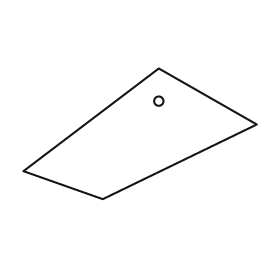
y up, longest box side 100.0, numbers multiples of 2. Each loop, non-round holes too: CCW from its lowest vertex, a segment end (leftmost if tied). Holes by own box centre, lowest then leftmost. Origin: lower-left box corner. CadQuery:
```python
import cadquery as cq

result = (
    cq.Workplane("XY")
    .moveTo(34.0, 0.0)
    .lineTo(100.0, 32.0)
    .lineTo(58.0, 56.0)
    .lineTo(0.0, 12.0)
    .close()
    .moveTo(58.0, 42.0)
    .circle(2.0)
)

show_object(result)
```